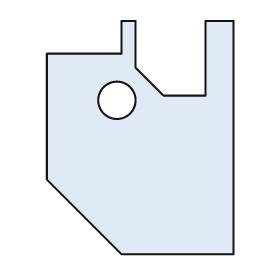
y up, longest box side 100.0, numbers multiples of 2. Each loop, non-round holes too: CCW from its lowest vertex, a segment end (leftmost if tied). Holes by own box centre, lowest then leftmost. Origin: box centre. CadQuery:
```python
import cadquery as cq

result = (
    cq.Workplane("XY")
    .moveTo(-8.0, -50.0)
    .lineTo(40.0, -50.0)
    .lineTo(40.0, 50.0)
    .lineTo(28.0, 50.0)
    .lineTo(28.0, 18.0)
    .lineTo(10.0, 18.0)
    .lineTo(-2.0, 30.0)
    .lineTo(-2.0, 50.0)
    .lineTo(-8.0, 50.0)
    .lineTo(-8.0, 36.0)
    .lineTo(-40.0, 36.0)
    .lineTo(-40.0, -18.0)
    .close()
    .moveTo(-10.0, 16.0)
    .circle(8.0)
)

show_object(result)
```